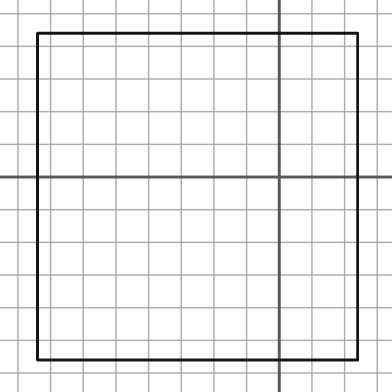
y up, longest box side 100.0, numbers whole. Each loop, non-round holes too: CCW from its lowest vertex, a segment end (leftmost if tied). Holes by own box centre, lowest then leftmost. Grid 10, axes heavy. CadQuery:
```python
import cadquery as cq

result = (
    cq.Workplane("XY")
    .moveTo(-74.0, -56.0)
    .lineTo(24.0, -56.0)
    .lineTo(24.0, 44.0)
    .lineTo(-74.0, 44.0)
    .close()
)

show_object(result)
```